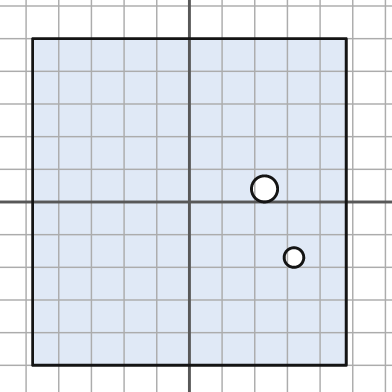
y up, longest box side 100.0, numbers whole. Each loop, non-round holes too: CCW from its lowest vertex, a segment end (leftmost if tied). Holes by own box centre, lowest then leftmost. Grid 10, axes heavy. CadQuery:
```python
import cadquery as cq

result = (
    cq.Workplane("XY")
    .moveTo(-48.0, -50.0)
    .lineTo(48.0, -50.0)
    .lineTo(48.0, 50.0)
    .lineTo(-48.0, 50.0)
    .close()
    .moveTo(32.0, -17.0)
    .circle(3.0)
    .moveTo(23.0, 4.0)
    .circle(4.0)
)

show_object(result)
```